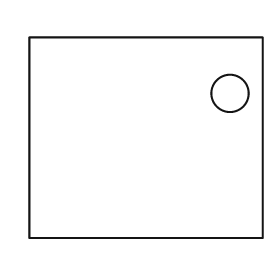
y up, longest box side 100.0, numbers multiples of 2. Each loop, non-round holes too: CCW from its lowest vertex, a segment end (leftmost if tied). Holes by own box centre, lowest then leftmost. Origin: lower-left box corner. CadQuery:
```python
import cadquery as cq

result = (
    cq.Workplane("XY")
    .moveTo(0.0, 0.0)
    .lineTo(100.0, 0.0)
    .lineTo(100.0, 86.0)
    .lineTo(0.0, 86.0)
    .close()
    .moveTo(86.0, 62.0)
    .circle(8.0)
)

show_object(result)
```